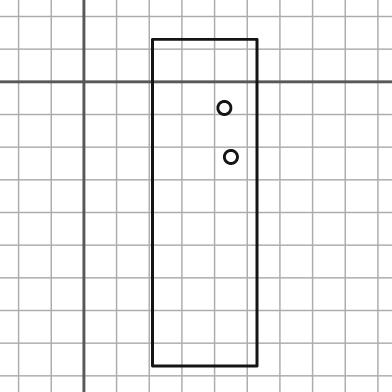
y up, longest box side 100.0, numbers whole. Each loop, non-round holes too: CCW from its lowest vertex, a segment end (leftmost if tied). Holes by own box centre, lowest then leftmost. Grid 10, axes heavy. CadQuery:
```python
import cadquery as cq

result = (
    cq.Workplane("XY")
    .moveTo(21.0, -87.0)
    .lineTo(53.0, -87.0)
    .lineTo(53.0, 13.0)
    .lineTo(21.0, 13.0)
    .close()
    .moveTo(45.0, -23.0)
    .circle(2.0)
    .moveTo(43.0, -8.0)
    .circle(2.0)
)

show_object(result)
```